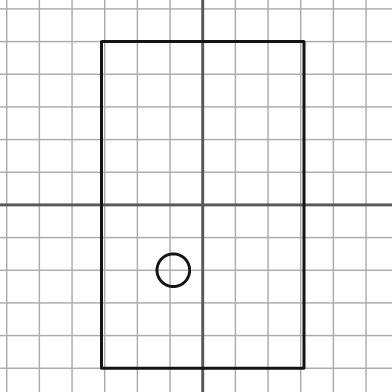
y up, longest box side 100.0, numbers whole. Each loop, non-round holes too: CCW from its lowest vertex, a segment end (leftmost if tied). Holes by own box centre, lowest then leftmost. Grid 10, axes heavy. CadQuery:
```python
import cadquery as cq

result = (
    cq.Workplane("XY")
    .moveTo(-31.0, -50.0)
    .lineTo(31.0, -50.0)
    .lineTo(31.0, 50.0)
    .lineTo(-31.0, 50.0)
    .close()
    .moveTo(-9.0, -20.0)
    .circle(5.0)
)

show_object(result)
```